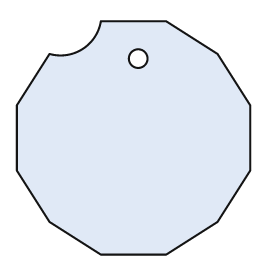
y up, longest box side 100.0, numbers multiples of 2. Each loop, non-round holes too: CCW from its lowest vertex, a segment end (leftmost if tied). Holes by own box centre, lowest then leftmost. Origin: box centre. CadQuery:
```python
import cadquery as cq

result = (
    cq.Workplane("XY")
    .moveTo(-14.0, -50.0)
    .lineTo(14.0, -50.0)
    .lineTo(36.0, -36.0)
    .lineTo(50.0, -14.0)
    .lineTo(50.0, 14.0)
    .lineTo(36.0, 36.0)
    .lineTo(14.0, 50.0)
    .lineTo(-14.0, 50.0)
    .threePointArc((-22.0, 38.0), (-36.0, 36.0))
    .lineTo(-50.0, 14.0)
    .lineTo(-50.0, -14.0)
    .lineTo(-36.0, -36.0)
    .close()
    .moveTo(2.0, 34.0)
    .circle(4.0)
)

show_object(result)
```